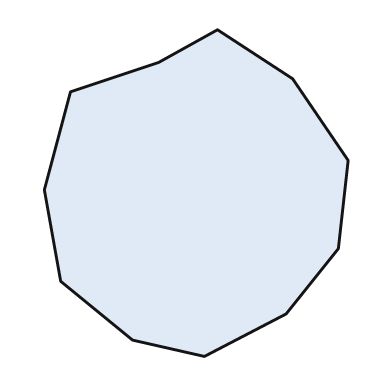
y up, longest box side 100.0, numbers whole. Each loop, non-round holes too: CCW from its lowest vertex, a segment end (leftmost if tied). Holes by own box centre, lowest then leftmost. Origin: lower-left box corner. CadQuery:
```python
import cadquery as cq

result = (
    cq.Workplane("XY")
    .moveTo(49.0, 0.0)
    .lineTo(74.0, 13.0)
    .lineTo(90.0, 33.0)
    .lineTo(93.0, 60.0)
    .lineTo(76.0, 85.0)
    .lineTo(53.0, 100.0)
    .lineTo(35.0, 90.0)
    .lineTo(8.0, 81.0)
    .lineTo(0.0, 51.0)
    .lineTo(5.0, 23.0)
    .lineTo(27.0, 5.0)
    .close()
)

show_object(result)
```